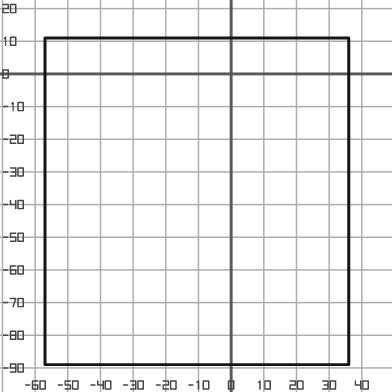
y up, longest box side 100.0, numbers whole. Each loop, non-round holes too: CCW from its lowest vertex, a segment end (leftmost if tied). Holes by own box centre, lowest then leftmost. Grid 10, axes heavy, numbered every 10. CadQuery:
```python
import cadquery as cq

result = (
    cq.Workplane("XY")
    .moveTo(-57.0, -89.0)
    .lineTo(36.0, -89.0)
    .lineTo(36.0, 11.0)
    .lineTo(-57.0, 11.0)
    .close()
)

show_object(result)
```